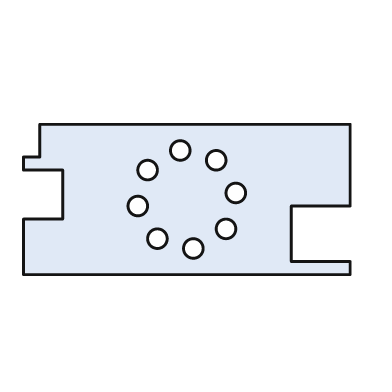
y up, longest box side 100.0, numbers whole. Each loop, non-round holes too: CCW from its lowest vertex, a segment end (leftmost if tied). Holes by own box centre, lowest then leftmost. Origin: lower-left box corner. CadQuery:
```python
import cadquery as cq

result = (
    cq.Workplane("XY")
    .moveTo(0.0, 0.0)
    .lineTo(100.0, 0.0)
    .lineTo(100.0, 4.0)
    .lineTo(82.0, 4.0)
    .lineTo(82.0, 21.0)
    .lineTo(100.0, 21.0)
    .lineTo(100.0, 46.0)
    .lineTo(5.0, 46.0)
    .lineTo(5.0, 36.0)
    .lineTo(0.0, 36.0)
    .lineTo(0.0, 32.0)
    .lineTo(12.0, 32.0)
    .lineTo(12.0, 17.0)
    .lineTo(0.0, 17.0)
    .close()
    .moveTo(52.0, 8.0)
    .circle(3.0)
    .moveTo(41.0, 11.0)
    .circle(3.0)
    .moveTo(62.0, 14.0)
    .circle(3.0)
    .moveTo(35.0, 21.0)
    .circle(3.0)
    .moveTo(65.0, 25.0)
    .circle(3.0)
    .moveTo(38.0, 32.0)
    .circle(3.0)
    .moveTo(59.0, 35.0)
    .circle(3.0)
    .moveTo(48.0, 38.0)
    .circle(3.0)
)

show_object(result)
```